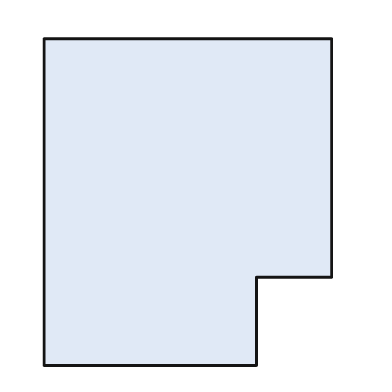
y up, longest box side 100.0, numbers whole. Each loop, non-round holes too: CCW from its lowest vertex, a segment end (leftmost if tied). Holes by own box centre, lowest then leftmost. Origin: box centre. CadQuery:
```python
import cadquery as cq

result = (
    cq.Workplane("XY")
    .moveTo(-44.0, -50.0)
    .lineTo(21.0, -50.0)
    .lineTo(21.0, -23.0)
    .lineTo(44.0, -23.0)
    .lineTo(44.0, 50.0)
    .lineTo(-44.0, 50.0)
    .close()
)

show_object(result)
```